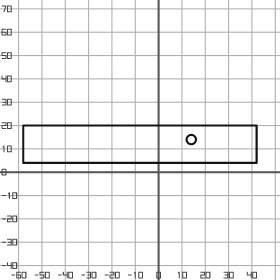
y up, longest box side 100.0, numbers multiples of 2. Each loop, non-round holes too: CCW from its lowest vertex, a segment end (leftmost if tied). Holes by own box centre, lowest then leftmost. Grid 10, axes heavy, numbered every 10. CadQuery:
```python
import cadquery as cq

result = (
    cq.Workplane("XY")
    .moveTo(-58.0, 4.0)
    .lineTo(42.0, 4.0)
    .lineTo(42.0, 20.0)
    .lineTo(-58.0, 20.0)
    .close()
    .moveTo(14.0, 14.0)
    .circle(2.0)
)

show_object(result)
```